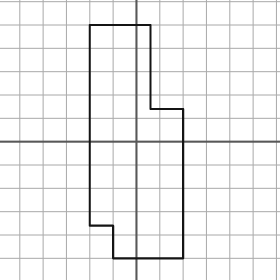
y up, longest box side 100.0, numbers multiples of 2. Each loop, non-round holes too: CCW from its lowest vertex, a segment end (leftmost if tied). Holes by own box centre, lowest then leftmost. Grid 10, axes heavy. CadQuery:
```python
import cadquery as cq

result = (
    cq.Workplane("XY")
    .moveTo(-10.0, -50.0)
    .lineTo(20.0, -50.0)
    .lineTo(20.0, 14.0)
    .lineTo(6.0, 14.0)
    .lineTo(6.0, 50.0)
    .lineTo(-20.0, 50.0)
    .lineTo(-20.0, -36.0)
    .lineTo(-10.0, -36.0)
    .close()
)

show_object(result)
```